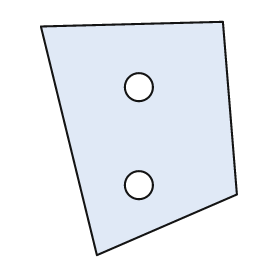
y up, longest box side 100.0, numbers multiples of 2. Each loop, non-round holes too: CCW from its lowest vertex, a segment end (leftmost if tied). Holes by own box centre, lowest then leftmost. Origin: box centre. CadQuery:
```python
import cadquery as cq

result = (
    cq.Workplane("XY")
    .moveTo(-18.0, -50.0)
    .lineTo(42.0, -24.0)
    .lineTo(36.0, 50.0)
    .lineTo(-42.0, 48.0)
    .close()
    .moveTo(0.0, -20.0)
    .circle(6.0)
    .moveTo(0.0, 22.0)
    .circle(6.0)
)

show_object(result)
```